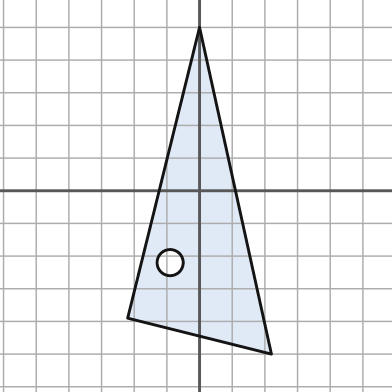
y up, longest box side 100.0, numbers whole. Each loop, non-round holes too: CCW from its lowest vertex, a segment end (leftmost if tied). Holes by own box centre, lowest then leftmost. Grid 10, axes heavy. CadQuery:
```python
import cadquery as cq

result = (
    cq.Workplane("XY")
    .moveTo(22.0, -50.0)
    .lineTo(0.0, 50.0)
    .lineTo(-22.0, -39.0)
    .close()
    .moveTo(-9.0, -22.0)
    .circle(4.0)
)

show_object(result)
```